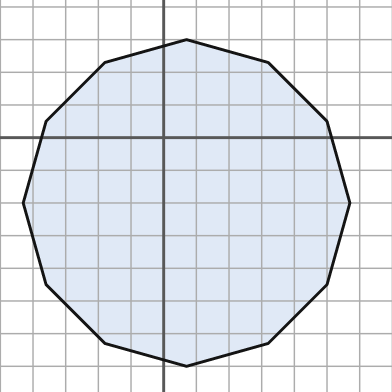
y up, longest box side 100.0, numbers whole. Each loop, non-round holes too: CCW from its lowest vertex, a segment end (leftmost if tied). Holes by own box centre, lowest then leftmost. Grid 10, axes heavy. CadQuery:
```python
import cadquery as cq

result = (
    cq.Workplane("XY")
    .moveTo(7.0, -70.0)
    .lineTo(32.0, -63.0)
    .lineTo(50.0, -45.0)
    .lineTo(57.0, -20.0)
    .lineTo(50.0, 5.0)
    .lineTo(32.0, 23.0)
    .lineTo(7.0, 30.0)
    .lineTo(-18.0, 23.0)
    .lineTo(-36.0, 5.0)
    .lineTo(-43.0, -20.0)
    .lineTo(-36.0, -45.0)
    .lineTo(-18.0, -63.0)
    .close()
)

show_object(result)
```